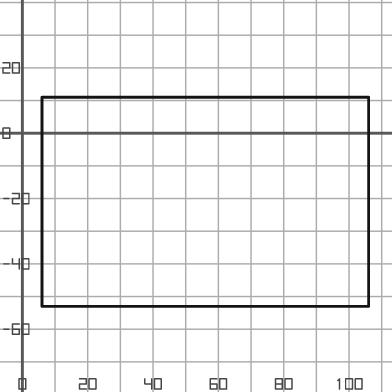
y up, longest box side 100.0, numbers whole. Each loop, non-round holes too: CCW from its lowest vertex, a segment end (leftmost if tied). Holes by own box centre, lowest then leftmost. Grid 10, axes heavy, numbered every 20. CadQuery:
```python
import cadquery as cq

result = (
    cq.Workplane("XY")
    .moveTo(6.0, -53.0)
    .lineTo(106.0, -53.0)
    .lineTo(106.0, 11.0)
    .lineTo(6.0, 11.0)
    .close()
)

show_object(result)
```